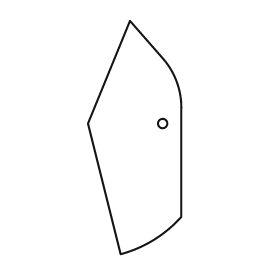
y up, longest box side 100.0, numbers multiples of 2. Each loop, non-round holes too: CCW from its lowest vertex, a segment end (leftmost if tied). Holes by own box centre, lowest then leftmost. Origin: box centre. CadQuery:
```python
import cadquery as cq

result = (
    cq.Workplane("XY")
    .moveTo(-6.0, -50.0)
    .threePointArc((8.0, -44.0), (20.0, -34.0))
    .lineTo(20.0, 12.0)
    .threePointArc((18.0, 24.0), (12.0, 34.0))
    .lineTo(-2.0, 50.0)
    .lineTo(-20.0, 6.0)
    .close()
    .moveTo(12.0, 6.0)
    .circle(2.0)
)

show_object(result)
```